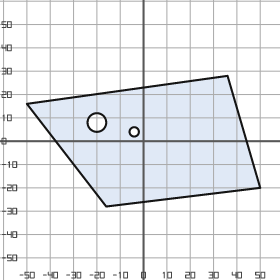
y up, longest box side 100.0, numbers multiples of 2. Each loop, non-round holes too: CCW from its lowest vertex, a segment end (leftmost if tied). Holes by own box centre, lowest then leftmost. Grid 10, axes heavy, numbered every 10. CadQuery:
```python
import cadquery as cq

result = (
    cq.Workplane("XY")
    .moveTo(-16.0, -28.0)
    .lineTo(50.0, -20.0)
    .lineTo(36.0, 28.0)
    .lineTo(-50.0, 16.0)
    .close()
    .moveTo(-4.0, 4.0)
    .circle(2.0)
    .moveTo(-20.0, 8.0)
    .circle(4.0)
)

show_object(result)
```